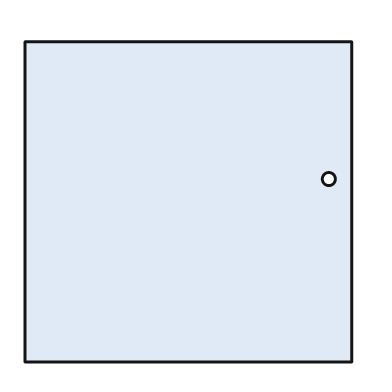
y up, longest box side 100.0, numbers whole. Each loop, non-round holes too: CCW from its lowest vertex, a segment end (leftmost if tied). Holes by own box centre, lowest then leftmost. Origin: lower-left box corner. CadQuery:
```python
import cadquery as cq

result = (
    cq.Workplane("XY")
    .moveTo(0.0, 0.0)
    .lineTo(100.0, 0.0)
    .lineTo(100.0, 98.0)
    .lineTo(0.0, 98.0)
    .close()
    .moveTo(93.0, 56.0)
    .circle(2.0)
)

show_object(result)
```